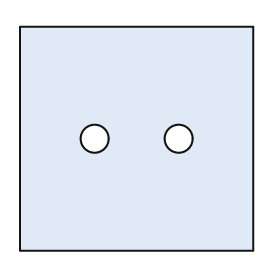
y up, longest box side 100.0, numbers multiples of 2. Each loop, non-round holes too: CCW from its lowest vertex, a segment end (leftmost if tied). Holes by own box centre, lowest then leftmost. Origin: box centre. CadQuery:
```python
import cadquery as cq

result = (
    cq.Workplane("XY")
    .moveTo(-50.0, -48.0)
    .lineTo(50.0, -48.0)
    .lineTo(50.0, 48.0)
    .lineTo(-50.0, 48.0)
    .close()
    .moveTo(-18.0, 0.0)
    .circle(6.0)
    .moveTo(18.0, 0.0)
    .circle(6.0)
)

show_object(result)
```